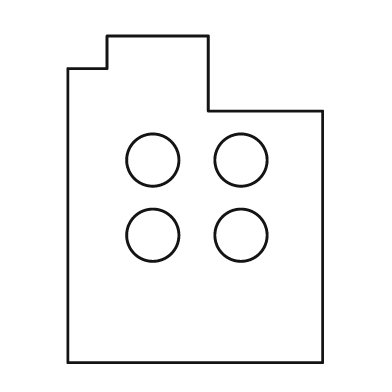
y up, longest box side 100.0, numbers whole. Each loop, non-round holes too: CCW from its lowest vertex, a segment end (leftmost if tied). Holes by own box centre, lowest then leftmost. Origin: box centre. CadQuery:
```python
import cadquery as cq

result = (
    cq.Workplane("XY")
    .moveTo(-39.0, -50.0)
    .lineTo(39.0, -50.0)
    .lineTo(39.0, 27.0)
    .lineTo(4.0, 27.0)
    .lineTo(4.0, 50.0)
    .lineTo(-27.0, 50.0)
    .lineTo(-27.0, 40.0)
    .lineTo(-39.0, 40.0)
    .close()
    .moveTo(-13.0, -11.0)
    .circle(8.0)
    .moveTo(14.0, -11.0)
    .circle(8.0)
    .moveTo(-13.0, 12.0)
    .circle(8.0)
    .moveTo(14.0, 12.0)
    .circle(8.0)
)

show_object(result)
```